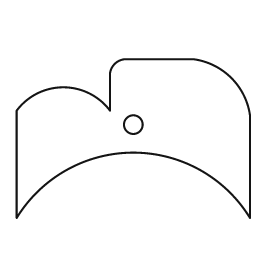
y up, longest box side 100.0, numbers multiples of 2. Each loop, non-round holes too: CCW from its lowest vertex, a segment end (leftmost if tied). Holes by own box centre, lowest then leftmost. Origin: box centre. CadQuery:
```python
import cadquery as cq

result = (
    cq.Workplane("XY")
    .moveTo(-50.0, -34.0)
    .threePointArc((0.0, -6.0), (50.0, -34.0))
    .lineTo(50.0, 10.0)
    .threePointArc((42.0, 26.0), (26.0, 34.0))
    .lineTo(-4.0, 34.0)
    .threePointArc((-8.0, 32.0), (-10.0, 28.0))
    .lineTo(-10.0, 12.0)
    .threePointArc((-30.0, 22.0), (-50.0, 12.0))
    .close()
    .moveTo(0.0, 6.0)
    .circle(4.0)
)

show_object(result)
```